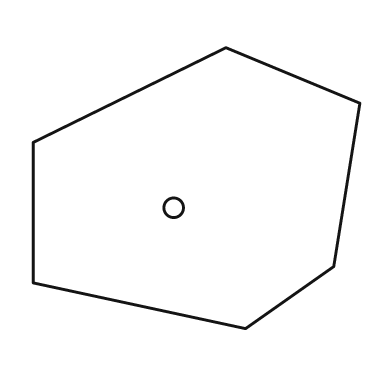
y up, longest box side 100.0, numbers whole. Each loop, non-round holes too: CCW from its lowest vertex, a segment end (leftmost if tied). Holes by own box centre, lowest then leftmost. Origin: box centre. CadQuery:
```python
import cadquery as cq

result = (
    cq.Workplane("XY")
    .moveTo(15.0, -43.0)
    .lineTo(42.0, -24.0)
    .lineTo(50.0, 26.0)
    .lineTo(9.0, 43.0)
    .lineTo(-50.0, 14.0)
    .lineTo(-50.0, -29.0)
    .close()
    .moveTo(-7.0, -6.0)
    .circle(3.0)
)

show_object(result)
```